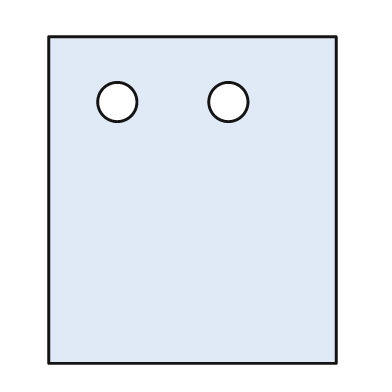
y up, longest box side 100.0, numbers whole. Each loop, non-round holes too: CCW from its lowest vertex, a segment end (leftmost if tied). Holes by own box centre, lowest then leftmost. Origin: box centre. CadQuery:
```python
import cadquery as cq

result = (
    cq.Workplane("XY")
    .moveTo(-44.0, -50.0)
    .lineTo(44.0, -50.0)
    .lineTo(44.0, 50.0)
    .lineTo(-44.0, 50.0)
    .close()
    .moveTo(-23.0, 30.0)
    .circle(6.0)
    .moveTo(11.0, 30.0)
    .circle(6.0)
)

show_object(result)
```